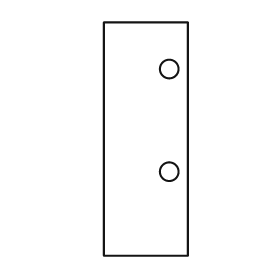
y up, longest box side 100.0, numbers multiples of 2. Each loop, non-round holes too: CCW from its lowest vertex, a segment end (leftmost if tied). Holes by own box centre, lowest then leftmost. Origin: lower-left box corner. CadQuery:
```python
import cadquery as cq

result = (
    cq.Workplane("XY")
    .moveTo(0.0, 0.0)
    .lineTo(36.0, 0.0)
    .lineTo(36.0, 100.0)
    .lineTo(0.0, 100.0)
    .close()
    .moveTo(28.0, 36.0)
    .circle(4.0)
    .moveTo(28.0, 80.0)
    .circle(4.0)
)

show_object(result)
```